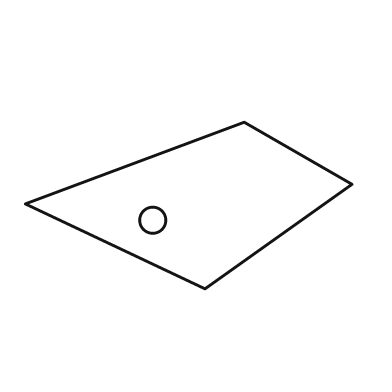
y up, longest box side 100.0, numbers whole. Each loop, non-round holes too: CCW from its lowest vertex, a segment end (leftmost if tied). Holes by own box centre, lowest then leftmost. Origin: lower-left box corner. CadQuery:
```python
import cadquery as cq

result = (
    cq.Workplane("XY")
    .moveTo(55.0, 0.0)
    .lineTo(100.0, 32.0)
    .lineTo(67.0, 51.0)
    .lineTo(0.0, 26.0)
    .close()
    .moveTo(39.0, 21.0)
    .circle(4.0)
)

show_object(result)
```